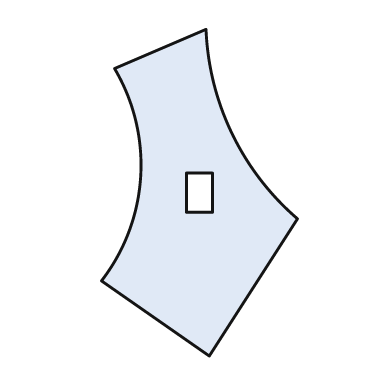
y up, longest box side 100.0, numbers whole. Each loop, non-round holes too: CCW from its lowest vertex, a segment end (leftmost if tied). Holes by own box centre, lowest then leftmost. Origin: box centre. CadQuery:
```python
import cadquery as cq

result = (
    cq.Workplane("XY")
    .moveTo(3.0, -50.0)
    .lineTo(30.0, -8.0)
    .threePointArc((10.0, 18.0), (2.0, 50.0))
    .lineTo(-26.0, 38.0)
    .threePointArc((-18.0, 5.0), (-30.0, -27.0))
    .close()
    .moveTo(-4.0, -6.0)
    .lineTo(4.0, -6.0)
    .lineTo(4.0, 6.0)
    .lineTo(-4.0, 6.0)
    .close()
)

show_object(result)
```